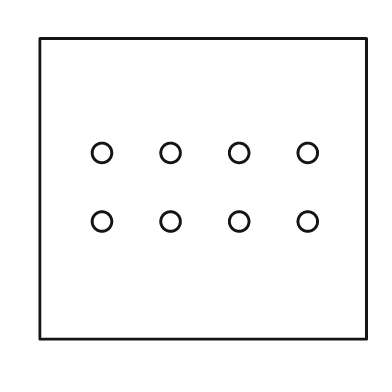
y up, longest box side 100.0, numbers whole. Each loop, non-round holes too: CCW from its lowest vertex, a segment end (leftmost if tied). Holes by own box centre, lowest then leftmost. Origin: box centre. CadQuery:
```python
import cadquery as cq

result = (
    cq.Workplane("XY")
    .moveTo(-50.0, -46.0)
    .lineTo(50.0, -46.0)
    .lineTo(50.0, 46.0)
    .lineTo(-50.0, 46.0)
    .close()
    .moveTo(-31.0, -10.0)
    .circle(3.0)
    .moveTo(-10.0, -10.0)
    .circle(3.0)
    .moveTo(11.0, -10.0)
    .circle(3.0)
    .moveTo(32.0, -10.0)
    .circle(3.0)
    .moveTo(-31.0, 11.0)
    .circle(3.0)
    .moveTo(-10.0, 11.0)
    .circle(3.0)
    .moveTo(11.0, 11.0)
    .circle(3.0)
    .moveTo(32.0, 11.0)
    .circle(3.0)
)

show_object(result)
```